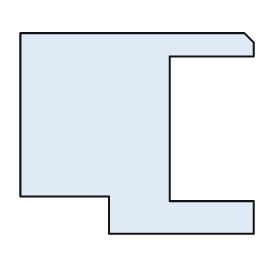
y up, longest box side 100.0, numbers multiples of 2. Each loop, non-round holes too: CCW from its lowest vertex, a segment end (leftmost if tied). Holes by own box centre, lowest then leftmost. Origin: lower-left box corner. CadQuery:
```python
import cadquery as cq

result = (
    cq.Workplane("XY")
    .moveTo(38.0, 0.0)
    .lineTo(100.0, 0.0)
    .lineTo(100.0, 14.0)
    .lineTo(64.0, 14.0)
    .lineTo(64.0, 76.0)
    .lineTo(100.0, 76.0)
    .lineTo(100.0, 82.0)
    .lineTo(96.0, 86.0)
    .lineTo(0.0, 86.0)
    .lineTo(0.0, 16.0)
    .lineTo(38.0, 16.0)
    .close()
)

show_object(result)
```